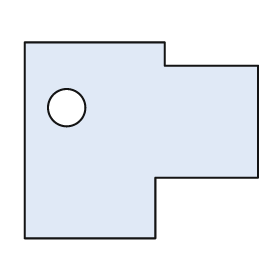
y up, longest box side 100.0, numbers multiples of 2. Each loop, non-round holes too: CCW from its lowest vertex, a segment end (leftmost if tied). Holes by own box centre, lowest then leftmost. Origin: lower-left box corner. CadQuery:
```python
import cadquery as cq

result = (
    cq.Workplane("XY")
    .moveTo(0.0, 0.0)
    .lineTo(56.0, 0.0)
    .lineTo(56.0, 26.0)
    .lineTo(100.0, 26.0)
    .lineTo(100.0, 74.0)
    .lineTo(60.0, 74.0)
    .lineTo(60.0, 84.0)
    .lineTo(0.0, 84.0)
    .close()
    .moveTo(18.0, 56.0)
    .circle(8.0)
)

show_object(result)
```